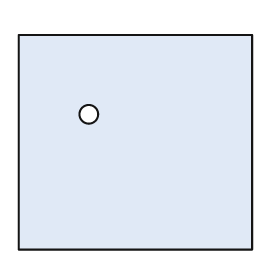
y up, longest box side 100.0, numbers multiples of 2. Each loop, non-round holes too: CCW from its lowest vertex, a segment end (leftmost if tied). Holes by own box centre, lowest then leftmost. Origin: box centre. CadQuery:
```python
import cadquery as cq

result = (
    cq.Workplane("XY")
    .moveTo(-50.0, -46.0)
    .lineTo(50.0, -46.0)
    .lineTo(50.0, 46.0)
    .lineTo(-50.0, 46.0)
    .close()
    .moveTo(-20.0, 12.0)
    .circle(4.0)
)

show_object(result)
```